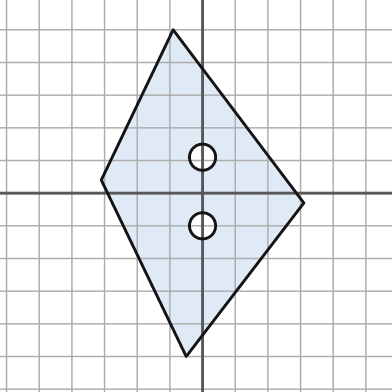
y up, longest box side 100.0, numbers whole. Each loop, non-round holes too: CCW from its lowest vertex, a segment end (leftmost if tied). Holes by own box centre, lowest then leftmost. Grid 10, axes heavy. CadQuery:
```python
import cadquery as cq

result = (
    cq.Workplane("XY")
    .moveTo(-5.0, -50.0)
    .lineTo(31.0, -3.0)
    .lineTo(-9.0, 50.0)
    .lineTo(-31.0, 4.0)
    .close()
    .moveTo(0.0, -10.0)
    .circle(4.0)
    .moveTo(0.0, 11.0)
    .circle(4.0)
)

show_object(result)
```